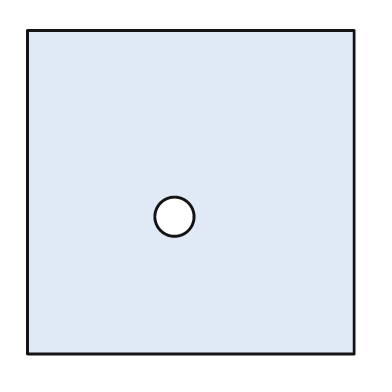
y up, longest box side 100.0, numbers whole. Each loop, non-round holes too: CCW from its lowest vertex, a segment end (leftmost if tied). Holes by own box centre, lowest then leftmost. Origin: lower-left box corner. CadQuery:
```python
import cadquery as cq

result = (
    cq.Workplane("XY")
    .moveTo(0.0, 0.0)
    .lineTo(100.0, 0.0)
    .lineTo(100.0, 99.0)
    .lineTo(0.0, 99.0)
    .close()
    .moveTo(45.0, 42.0)
    .circle(6.0)
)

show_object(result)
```